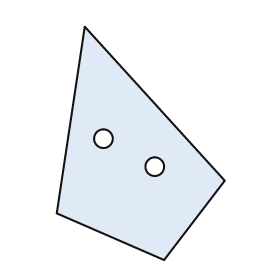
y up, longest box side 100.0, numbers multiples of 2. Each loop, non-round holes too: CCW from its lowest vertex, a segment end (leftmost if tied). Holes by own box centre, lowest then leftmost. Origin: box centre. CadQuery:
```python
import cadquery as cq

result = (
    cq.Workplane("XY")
    .moveTo(10.0, -50.0)
    .lineTo(36.0, -16.0)
    .lineTo(-24.0, 50.0)
    .lineTo(-36.0, -30.0)
    .close()
    .moveTo(6.0, -10.0)
    .circle(4.0)
    .moveTo(-16.0, 2.0)
    .circle(4.0)
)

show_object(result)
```